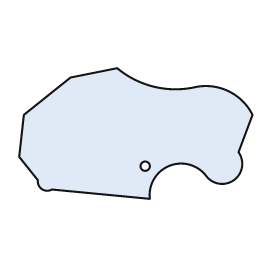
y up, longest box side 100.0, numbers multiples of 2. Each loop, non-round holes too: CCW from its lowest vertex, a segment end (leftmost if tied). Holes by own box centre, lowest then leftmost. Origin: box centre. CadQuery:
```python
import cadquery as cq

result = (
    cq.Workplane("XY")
    .moveTo(6.0, -28.0)
    .threePointArc((14.0, -14.0), (30.0, -18.0))
    .threePointArc((42.0, -20.0), (44.0, -8.0))
    .lineTo(50.0, 8.0)
    .threePointArc((40.0, 18.0), (26.0, 20.0))
    .threePointArc((8.0, 20.0), (-8.0, 28.0))
    .lineTo(-28.0, 24.0)
    .lineTo(-48.0, 8.0)
    .lineTo(-50.0, -10.0)
    .lineTo(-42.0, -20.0)
    .threePointArc((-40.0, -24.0), (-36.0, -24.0))
    .close()
    .moveTo(4.0, -14.0)
    .circle(2.0)
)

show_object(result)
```